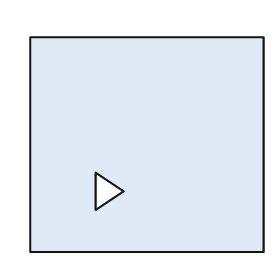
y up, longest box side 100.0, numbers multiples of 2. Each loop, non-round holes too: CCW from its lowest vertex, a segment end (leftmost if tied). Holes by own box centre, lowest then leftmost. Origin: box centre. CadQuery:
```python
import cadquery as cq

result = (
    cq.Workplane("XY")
    .moveTo(-50.0, -46.0)
    .lineTo(50.0, -46.0)
    .lineTo(50.0, 46.0)
    .lineTo(-50.0, 46.0)
    .close()
    .moveTo(-22.0, -28.0)
    .lineTo(-10.0, -20.0)
    .lineTo(-22.0, -12.0)
    .close()
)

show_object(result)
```